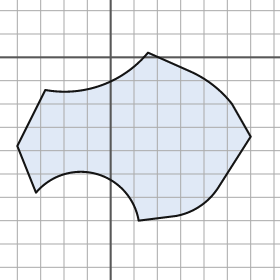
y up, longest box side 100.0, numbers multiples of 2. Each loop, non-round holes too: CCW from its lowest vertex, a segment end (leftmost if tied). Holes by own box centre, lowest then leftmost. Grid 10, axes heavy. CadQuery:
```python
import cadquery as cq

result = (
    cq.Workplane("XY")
    .moveTo(12.0, -70.0)
    .lineTo(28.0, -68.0)
    .threePointArc((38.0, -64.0), (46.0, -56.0))
    .lineTo(60.0, -34.0)
    .lineTo(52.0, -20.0)
    .threePointArc((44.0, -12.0), (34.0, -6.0))
    .lineTo(16.0, 2.0)
    .threePointArc((-4.0, -12.0), (-28.0, -14.0))
    .lineTo(-40.0, -38.0)
    .lineTo(-32.0, -58.0)
    .threePointArc((-6.0, -50.0), (12.0, -70.0))
    .close()
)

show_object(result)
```